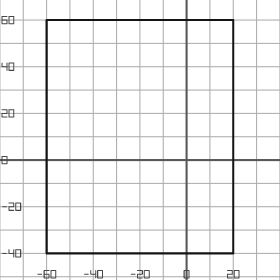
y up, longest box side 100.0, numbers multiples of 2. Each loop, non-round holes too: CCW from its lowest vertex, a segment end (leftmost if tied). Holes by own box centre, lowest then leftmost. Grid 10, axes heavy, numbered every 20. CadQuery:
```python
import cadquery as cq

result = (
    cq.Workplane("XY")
    .moveTo(-60.0, -40.0)
    .lineTo(20.0, -40.0)
    .lineTo(20.0, 60.0)
    .lineTo(-60.0, 60.0)
    .close()
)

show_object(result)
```